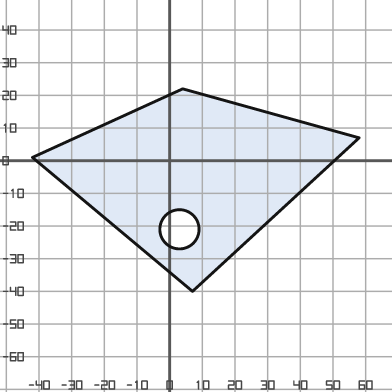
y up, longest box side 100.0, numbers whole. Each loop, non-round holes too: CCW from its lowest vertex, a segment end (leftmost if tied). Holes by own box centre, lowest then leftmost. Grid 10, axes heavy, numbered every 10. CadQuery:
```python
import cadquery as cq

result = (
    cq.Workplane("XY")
    .moveTo(7.0, -40.0)
    .lineTo(58.0, 7.0)
    .lineTo(4.0, 22.0)
    .lineTo(-42.0, 1.0)
    .close()
    .moveTo(3.0, -21.0)
    .circle(6.0)
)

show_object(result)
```